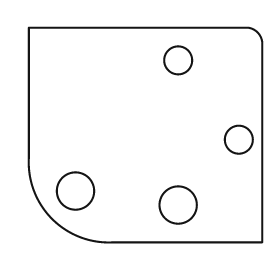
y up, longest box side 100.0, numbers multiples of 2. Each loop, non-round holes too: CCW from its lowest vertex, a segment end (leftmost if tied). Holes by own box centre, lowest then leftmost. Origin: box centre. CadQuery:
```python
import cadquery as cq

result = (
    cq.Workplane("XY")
    .moveTo(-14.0, -46.0)
    .lineTo(50.0, -46.0)
    .lineTo(50.0, 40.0)
    .threePointArc((48.0, 44.0), (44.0, 46.0))
    .lineTo(-50.0, 46.0)
    .lineTo(-50.0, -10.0)
    .threePointArc((-40.0, -36.0), (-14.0, -46.0))
    .close()
    .moveTo(14.0, -30.0)
    .circle(8.0)
    .moveTo(-30.0, -24.0)
    .circle(8.0)
    .moveTo(40.0, -2.0)
    .circle(6.0)
    .moveTo(14.0, 32.0)
    .circle(6.0)
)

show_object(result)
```